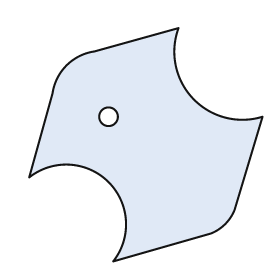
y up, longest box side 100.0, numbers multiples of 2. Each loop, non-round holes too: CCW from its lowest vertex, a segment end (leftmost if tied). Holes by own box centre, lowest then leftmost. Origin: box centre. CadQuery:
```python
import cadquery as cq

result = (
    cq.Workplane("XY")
    .moveTo(-14.0, -50.0)
    .lineTo(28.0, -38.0)
    .threePointArc((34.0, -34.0), (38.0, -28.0))
    .lineTo(50.0, 12.0)
    .threePointArc((20.0, 20.0), (14.0, 50.0))
    .lineTo(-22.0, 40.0)
    .threePointArc((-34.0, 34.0), (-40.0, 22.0))
    .lineTo(-50.0, -14.0)
    .threePointArc((-16.0, -16.0), (-14.0, -50.0))
    .close()
    .moveTo(-16.0, 12.0)
    .circle(4.0)
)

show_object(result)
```